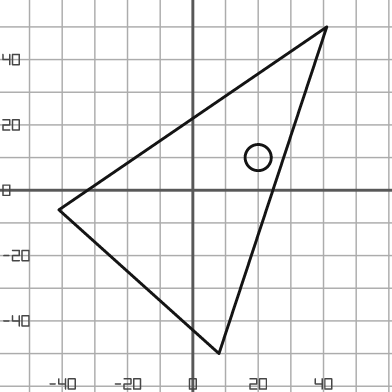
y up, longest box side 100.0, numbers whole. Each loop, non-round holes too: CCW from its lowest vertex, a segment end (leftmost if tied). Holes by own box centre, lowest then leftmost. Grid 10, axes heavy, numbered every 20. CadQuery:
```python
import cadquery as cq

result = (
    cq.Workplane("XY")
    .moveTo(8.0, -50.0)
    .lineTo(41.0, 50.0)
    .lineTo(-41.0, -6.0)
    .close()
    .moveTo(20.0, 10.0)
    .circle(4.0)
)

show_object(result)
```